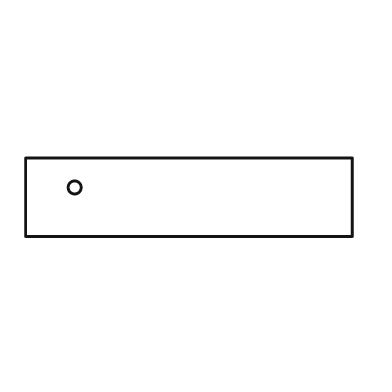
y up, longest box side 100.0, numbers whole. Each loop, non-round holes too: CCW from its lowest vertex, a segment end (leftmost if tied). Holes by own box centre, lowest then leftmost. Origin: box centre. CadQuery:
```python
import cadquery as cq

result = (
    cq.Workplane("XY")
    .moveTo(-50.0, -12.0)
    .lineTo(50.0, -12.0)
    .lineTo(50.0, 12.0)
    .lineTo(-50.0, 12.0)
    .close()
    .moveTo(-35.0, 3.0)
    .circle(2.0)
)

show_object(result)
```